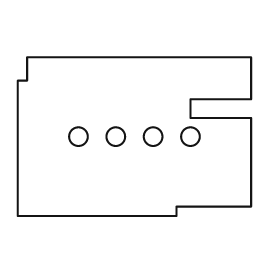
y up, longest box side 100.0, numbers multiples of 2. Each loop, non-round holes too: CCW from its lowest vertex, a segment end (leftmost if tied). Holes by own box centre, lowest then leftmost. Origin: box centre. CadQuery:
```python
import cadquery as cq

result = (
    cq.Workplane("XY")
    .moveTo(-50.0, -34.0)
    .lineTo(18.0, -34.0)
    .lineTo(18.0, -30.0)
    .lineTo(50.0, -30.0)
    .lineTo(50.0, 8.0)
    .lineTo(24.0, 8.0)
    .lineTo(24.0, 16.0)
    .lineTo(50.0, 16.0)
    .lineTo(50.0, 34.0)
    .lineTo(-46.0, 34.0)
    .lineTo(-46.0, 24.0)
    .lineTo(-50.0, 24.0)
    .close()
    .moveTo(-24.0, 0.0)
    .circle(4.0)
    .moveTo(-8.0, 0.0)
    .circle(4.0)
    .moveTo(8.0, 0.0)
    .circle(4.0)
    .moveTo(24.0, 0.0)
    .circle(4.0)
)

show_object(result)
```